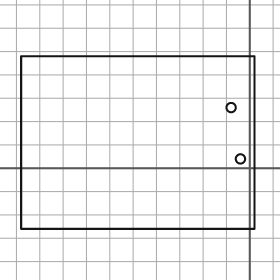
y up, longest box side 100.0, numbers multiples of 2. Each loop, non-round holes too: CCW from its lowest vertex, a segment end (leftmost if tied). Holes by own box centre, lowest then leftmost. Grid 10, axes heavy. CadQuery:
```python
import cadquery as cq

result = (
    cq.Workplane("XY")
    .moveTo(-98.0, -26.0)
    .lineTo(2.0, -26.0)
    .lineTo(2.0, 48.0)
    .lineTo(-98.0, 48.0)
    .close()
    .moveTo(-4.0, 4.0)
    .circle(2.0)
    .moveTo(-8.0, 26.0)
    .circle(2.0)
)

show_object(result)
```